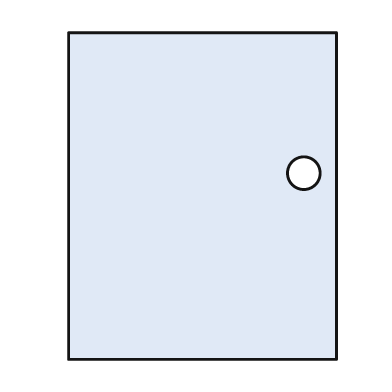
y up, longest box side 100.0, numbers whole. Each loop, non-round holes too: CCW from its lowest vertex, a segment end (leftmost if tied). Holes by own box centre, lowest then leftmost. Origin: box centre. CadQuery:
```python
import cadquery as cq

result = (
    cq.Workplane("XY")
    .moveTo(-41.0, -50.0)
    .lineTo(41.0, -50.0)
    .lineTo(41.0, 50.0)
    .lineTo(-41.0, 50.0)
    .close()
    .moveTo(31.0, 7.0)
    .circle(5.0)
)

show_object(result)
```